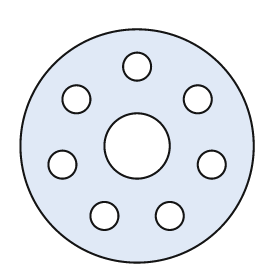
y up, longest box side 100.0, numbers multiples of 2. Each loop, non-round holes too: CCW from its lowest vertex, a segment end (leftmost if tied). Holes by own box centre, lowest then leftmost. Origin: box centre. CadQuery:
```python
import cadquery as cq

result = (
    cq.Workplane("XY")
    .moveTo(0.0, 0.0)
    .circle(50.0)
    .moveTo(-14.0, -30.0)
    .circle(6.0)
    .moveTo(14.0, -30.0)
    .circle(6.0)
    .moveTo(-32.0, -8.0)
    .circle(6.0)
    .moveTo(32.0, -8.0)
    .circle(6.0)
    .moveTo(0.0, 0.0)
    .circle(14.0)
    .moveTo(-26.0, 20.0)
    .circle(6.0)
    .moveTo(26.0, 20.0)
    .circle(6.0)
    .moveTo(0.0, 34.0)
    .circle(6.0)
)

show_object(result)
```